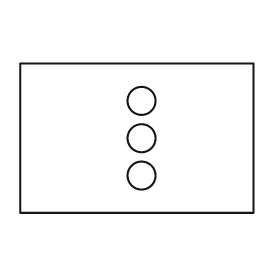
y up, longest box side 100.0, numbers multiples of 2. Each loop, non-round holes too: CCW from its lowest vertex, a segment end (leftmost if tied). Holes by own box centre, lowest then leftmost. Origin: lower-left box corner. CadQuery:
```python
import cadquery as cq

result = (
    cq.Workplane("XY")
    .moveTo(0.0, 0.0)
    .lineTo(100.0, 0.0)
    .lineTo(100.0, 64.0)
    .lineTo(0.0, 64.0)
    .close()
    .moveTo(52.0, 16.0)
    .circle(6.0)
    .moveTo(52.0, 32.0)
    .circle(6.0)
    .moveTo(52.0, 48.0)
    .circle(6.0)
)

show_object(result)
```